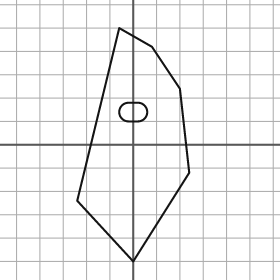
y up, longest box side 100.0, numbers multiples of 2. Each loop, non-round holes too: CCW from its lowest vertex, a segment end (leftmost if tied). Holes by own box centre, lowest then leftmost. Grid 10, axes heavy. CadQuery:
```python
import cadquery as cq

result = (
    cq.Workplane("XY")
    .moveTo(0.0, -50.0)
    .lineTo(24.0, -12.0)
    .lineTo(20.0, 24.0)
    .lineTo(8.0, 42.0)
    .lineTo(-6.0, 50.0)
    .lineTo(-24.0, -24.0)
    .close()
    .moveTo(-2.0, 10.0)
    .lineTo(2.0, 10.0)
    .threePointArc((6.0, 14.0), (2.0, 18.0))
    .lineTo(-2.0, 18.0)
    .threePointArc((-6.0, 14.0), (-2.0, 10.0))
    .close()
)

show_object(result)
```